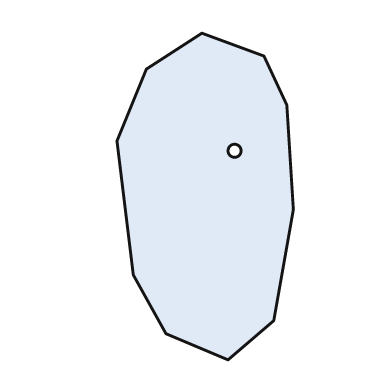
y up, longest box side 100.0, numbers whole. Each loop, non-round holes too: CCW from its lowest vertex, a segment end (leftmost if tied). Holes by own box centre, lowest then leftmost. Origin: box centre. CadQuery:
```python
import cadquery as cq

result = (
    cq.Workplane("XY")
    .moveTo(7.0, -50.0)
    .lineTo(21.0, -38.0)
    .lineTo(27.0, -4.0)
    .lineTo(25.0, 28.0)
    .lineTo(18.0, 43.0)
    .lineTo(-1.0, 50.0)
    .lineTo(-18.0, 39.0)
    .lineTo(-27.0, 17.0)
    .lineTo(-22.0, -24.0)
    .lineTo(-12.0, -42.0)
    .close()
    .moveTo(9.0, 14.0)
    .circle(2.0)
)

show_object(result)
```